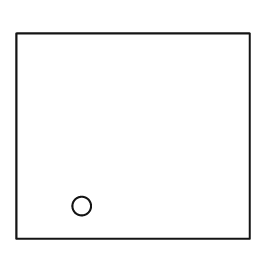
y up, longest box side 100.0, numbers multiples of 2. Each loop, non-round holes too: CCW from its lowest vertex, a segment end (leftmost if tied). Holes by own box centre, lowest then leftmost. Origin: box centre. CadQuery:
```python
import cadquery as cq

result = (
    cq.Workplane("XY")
    .moveTo(-50.0, -44.0)
    .lineTo(50.0, -44.0)
    .lineTo(50.0, 44.0)
    .lineTo(-50.0, 44.0)
    .close()
    .moveTo(-22.0, -30.0)
    .circle(4.0)
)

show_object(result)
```